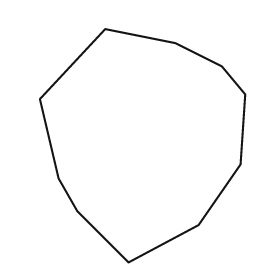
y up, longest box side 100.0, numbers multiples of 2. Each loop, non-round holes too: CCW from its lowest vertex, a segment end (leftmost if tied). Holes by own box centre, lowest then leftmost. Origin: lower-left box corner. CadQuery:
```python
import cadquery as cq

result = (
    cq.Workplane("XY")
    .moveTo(38.0, 0.0)
    .lineTo(68.0, 16.0)
    .lineTo(86.0, 42.0)
    .lineTo(88.0, 72.0)
    .lineTo(78.0, 84.0)
    .lineTo(58.0, 94.0)
    .lineTo(28.0, 100.0)
    .lineTo(0.0, 70.0)
    .lineTo(8.0, 36.0)
    .lineTo(16.0, 22.0)
    .close()
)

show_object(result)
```